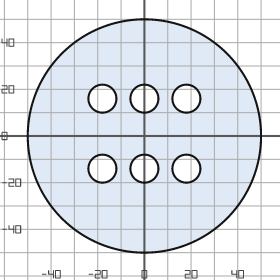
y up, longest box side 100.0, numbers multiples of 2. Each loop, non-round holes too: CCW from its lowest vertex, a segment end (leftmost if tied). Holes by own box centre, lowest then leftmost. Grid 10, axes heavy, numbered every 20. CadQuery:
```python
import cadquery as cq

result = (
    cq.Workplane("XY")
    .moveTo(0.0, 0.0)
    .circle(50.0)
    .moveTo(-18.0, -14.0)
    .circle(6.0)
    .moveTo(0.0, -14.0)
    .circle(6.0)
    .moveTo(18.0, -14.0)
    .circle(6.0)
    .moveTo(-18.0, 16.0)
    .circle(6.0)
    .moveTo(0.0, 16.0)
    .circle(6.0)
    .moveTo(18.0, 16.0)
    .circle(6.0)
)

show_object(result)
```